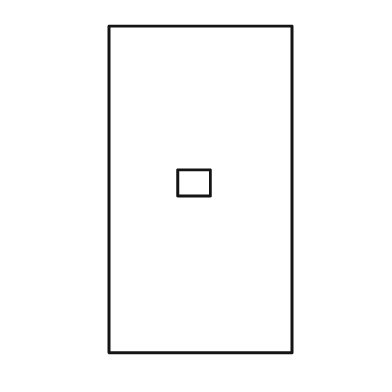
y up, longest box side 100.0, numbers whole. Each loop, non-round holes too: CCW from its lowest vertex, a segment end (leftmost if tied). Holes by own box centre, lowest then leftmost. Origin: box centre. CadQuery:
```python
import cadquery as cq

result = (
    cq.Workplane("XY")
    .moveTo(-28.0, -50.0)
    .lineTo(28.0, -50.0)
    .lineTo(28.0, 50.0)
    .lineTo(-28.0, 50.0)
    .close()
    .moveTo(-7.0, -2.0)
    .lineTo(3.0, -2.0)
    .lineTo(3.0, 6.0)
    .lineTo(-7.0, 6.0)
    .close()
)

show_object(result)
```